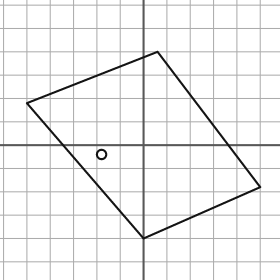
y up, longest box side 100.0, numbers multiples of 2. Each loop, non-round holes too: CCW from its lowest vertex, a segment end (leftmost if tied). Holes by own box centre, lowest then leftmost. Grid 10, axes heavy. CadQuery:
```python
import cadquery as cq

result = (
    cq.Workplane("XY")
    .moveTo(0.0, -40.0)
    .lineTo(50.0, -18.0)
    .lineTo(6.0, 40.0)
    .lineTo(-50.0, 18.0)
    .close()
    .moveTo(-18.0, -4.0)
    .circle(2.0)
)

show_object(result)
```